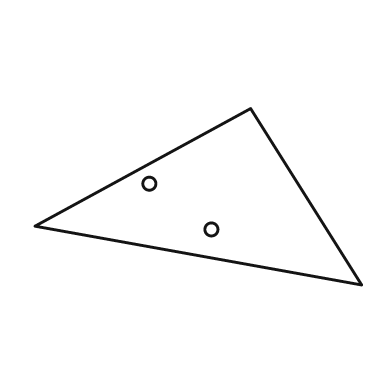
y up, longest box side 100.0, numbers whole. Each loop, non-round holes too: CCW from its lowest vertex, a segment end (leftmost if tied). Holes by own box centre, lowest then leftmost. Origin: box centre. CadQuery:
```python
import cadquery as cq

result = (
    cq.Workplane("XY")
    .moveTo(50.0, -27.0)
    .lineTo(16.0, 27.0)
    .lineTo(-50.0, -9.0)
    .close()
    .moveTo(4.0, -10.0)
    .circle(2.0)
    .moveTo(-15.0, 4.0)
    .circle(2.0)
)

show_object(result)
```